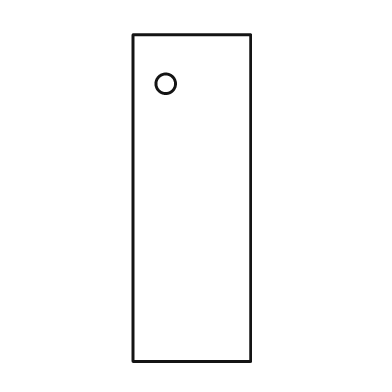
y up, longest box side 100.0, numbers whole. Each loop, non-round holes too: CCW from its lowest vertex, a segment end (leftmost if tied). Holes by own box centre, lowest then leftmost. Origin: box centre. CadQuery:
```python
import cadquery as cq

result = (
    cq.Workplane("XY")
    .moveTo(-18.0, -50.0)
    .lineTo(18.0, -50.0)
    .lineTo(18.0, 50.0)
    .lineTo(-18.0, 50.0)
    .close()
    .moveTo(-8.0, 35.0)
    .circle(3.0)
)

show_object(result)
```